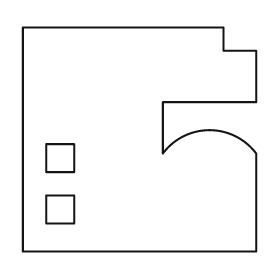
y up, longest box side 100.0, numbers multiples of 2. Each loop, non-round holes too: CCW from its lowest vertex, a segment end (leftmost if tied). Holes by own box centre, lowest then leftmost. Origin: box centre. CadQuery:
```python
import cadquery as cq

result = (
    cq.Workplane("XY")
    .moveTo(-50.0, -48.0)
    .lineTo(50.0, -48.0)
    .lineTo(50.0, -6.0)
    .threePointArc((30.0, 4.0), (10.0, -6.0))
    .lineTo(10.0, 16.0)
    .lineTo(50.0, 16.0)
    .lineTo(50.0, 38.0)
    .lineTo(36.0, 38.0)
    .lineTo(36.0, 48.0)
    .lineTo(-50.0, 48.0)
    .close()
    .moveTo(-40.0, -36.0)
    .lineTo(-28.0, -36.0)
    .lineTo(-28.0, -24.0)
    .lineTo(-40.0, -24.0)
    .close()
    .moveTo(-40.0, -14.0)
    .lineTo(-28.0, -14.0)
    .lineTo(-28.0, -2.0)
    .lineTo(-40.0, -2.0)
    .close()
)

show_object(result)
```